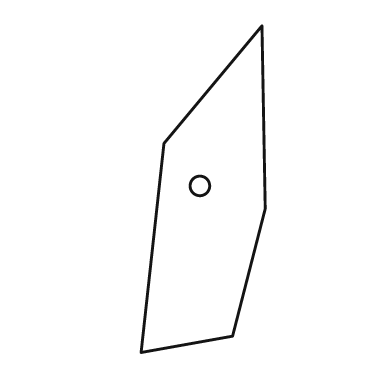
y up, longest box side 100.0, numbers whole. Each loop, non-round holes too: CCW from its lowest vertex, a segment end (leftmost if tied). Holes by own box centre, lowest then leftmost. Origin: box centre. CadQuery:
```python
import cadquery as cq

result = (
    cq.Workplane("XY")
    .moveTo(-19.0, -50.0)
    .lineTo(9.0, -45.0)
    .lineTo(19.0, -6.0)
    .lineTo(18.0, 50.0)
    .lineTo(-12.0, 14.0)
    .close()
    .moveTo(-1.0, 1.0)
    .circle(3.0)
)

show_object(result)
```